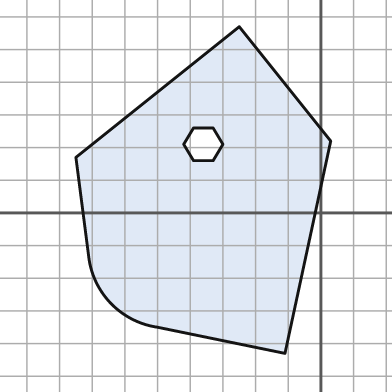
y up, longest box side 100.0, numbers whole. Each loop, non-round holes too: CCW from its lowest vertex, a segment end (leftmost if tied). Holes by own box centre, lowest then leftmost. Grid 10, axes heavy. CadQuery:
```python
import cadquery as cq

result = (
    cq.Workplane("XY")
    .moveTo(-11.0, -43.0)
    .lineTo(3.0, 22.0)
    .lineTo(-25.0, 57.0)
    .lineTo(-75.0, 17.0)
    .lineTo(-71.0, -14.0)
    .threePointArc((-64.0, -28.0), (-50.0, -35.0))
    .close()
    .moveTo(-39.0, 16.0)
    .lineTo(-33.0, 16.0)
    .lineTo(-30.0, 21.0)
    .lineTo(-33.0, 26.0)
    .lineTo(-39.0, 26.0)
    .lineTo(-42.0, 21.0)
    .close()
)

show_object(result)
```